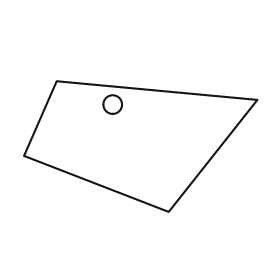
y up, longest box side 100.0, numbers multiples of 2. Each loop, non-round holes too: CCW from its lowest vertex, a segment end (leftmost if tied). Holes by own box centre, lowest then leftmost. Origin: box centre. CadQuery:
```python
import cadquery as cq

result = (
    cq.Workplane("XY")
    .moveTo(12.0, -28.0)
    .lineTo(50.0, 20.0)
    .lineTo(-36.0, 28.0)
    .lineTo(-50.0, -4.0)
    .close()
    .moveTo(-12.0, 18.0)
    .circle(4.0)
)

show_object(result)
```